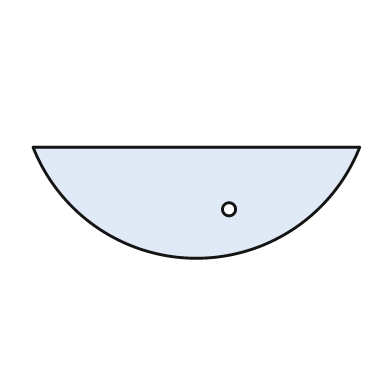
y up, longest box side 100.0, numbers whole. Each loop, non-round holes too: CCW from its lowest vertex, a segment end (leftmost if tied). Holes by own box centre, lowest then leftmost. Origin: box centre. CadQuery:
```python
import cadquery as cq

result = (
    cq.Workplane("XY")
    .moveTo(-50.0, 17.0)
    .threePointArc((0.0, -17.0), (50.0, 17.0))
    .close()
    .moveTo(10.0, -2.0)
    .circle(2.0)
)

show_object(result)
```